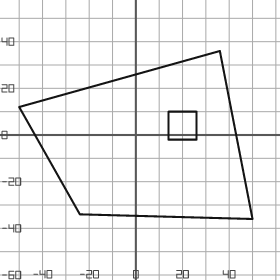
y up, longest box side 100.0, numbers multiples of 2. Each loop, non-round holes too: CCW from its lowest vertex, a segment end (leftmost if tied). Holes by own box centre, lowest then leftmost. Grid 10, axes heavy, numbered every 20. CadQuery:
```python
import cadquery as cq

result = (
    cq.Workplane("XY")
    .moveTo(50.0, -36.0)
    .lineTo(36.0, 36.0)
    .lineTo(-50.0, 12.0)
    .lineTo(-24.0, -34.0)
    .close()
    .moveTo(14.0, -2.0)
    .lineTo(26.0, -2.0)
    .lineTo(26.0, 10.0)
    .lineTo(14.0, 10.0)
    .close()
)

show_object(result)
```